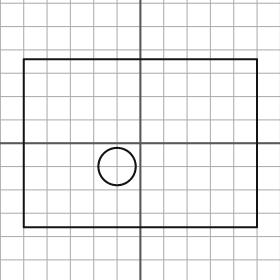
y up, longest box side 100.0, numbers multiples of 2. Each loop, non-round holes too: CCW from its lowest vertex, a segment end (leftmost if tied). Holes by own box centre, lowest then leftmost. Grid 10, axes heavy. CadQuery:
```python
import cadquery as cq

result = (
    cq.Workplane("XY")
    .moveTo(-50.0, -36.0)
    .lineTo(50.0, -36.0)
    .lineTo(50.0, 36.0)
    .lineTo(-50.0, 36.0)
    .close()
    .moveTo(-10.0, -10.0)
    .circle(8.0)
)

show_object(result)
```